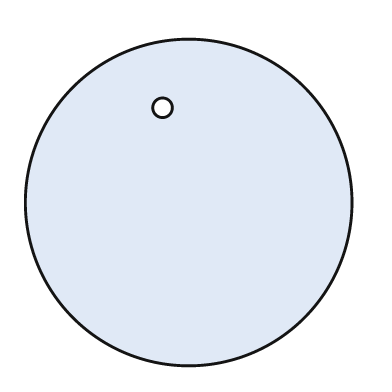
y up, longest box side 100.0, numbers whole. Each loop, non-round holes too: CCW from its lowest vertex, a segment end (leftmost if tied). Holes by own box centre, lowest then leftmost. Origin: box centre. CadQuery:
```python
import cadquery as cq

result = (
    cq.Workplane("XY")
    .moveTo(0.0, 0.0)
    .circle(50.0)
    .moveTo(-8.0, 29.0)
    .circle(3.0)
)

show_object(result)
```